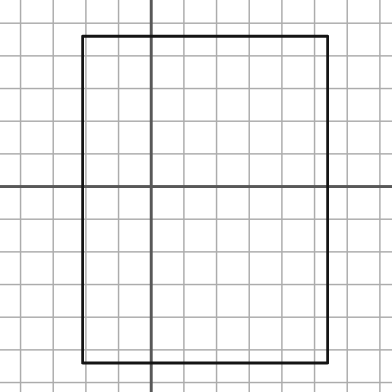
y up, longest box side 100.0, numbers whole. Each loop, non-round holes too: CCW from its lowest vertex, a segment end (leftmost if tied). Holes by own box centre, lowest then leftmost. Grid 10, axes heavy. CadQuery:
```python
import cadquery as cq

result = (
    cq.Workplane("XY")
    .moveTo(-21.0, -54.0)
    .lineTo(54.0, -54.0)
    .lineTo(54.0, 46.0)
    .lineTo(-21.0, 46.0)
    .close()
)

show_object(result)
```